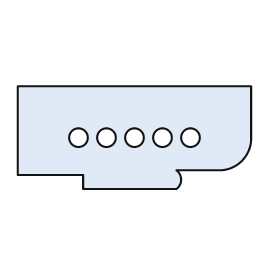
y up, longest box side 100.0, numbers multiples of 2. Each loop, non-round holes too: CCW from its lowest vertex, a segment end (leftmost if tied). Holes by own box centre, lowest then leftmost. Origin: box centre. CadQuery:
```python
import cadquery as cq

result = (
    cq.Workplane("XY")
    .moveTo(-22.0, -22.0)
    .lineTo(18.0, -22.0)
    .threePointArc((20.0, -18.0), (18.0, -14.0))
    .lineTo(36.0, -14.0)
    .threePointArc((46.0, -10.0), (50.0, 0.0))
    .lineTo(50.0, 22.0)
    .lineTo(-50.0, 22.0)
    .lineTo(-50.0, -16.0)
    .lineTo(-22.0, -16.0)
    .close()
    .moveTo(-24.0, 0.0)
    .circle(4.0)
    .moveTo(-12.0, 0.0)
    .circle(4.0)
    .moveTo(0.0, 0.0)
    .circle(4.0)
    .moveTo(12.0, 0.0)
    .circle(4.0)
    .moveTo(24.0, 0.0)
    .circle(4.0)
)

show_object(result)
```